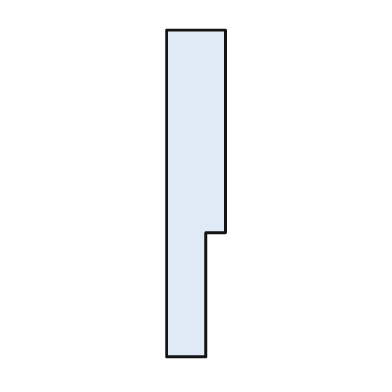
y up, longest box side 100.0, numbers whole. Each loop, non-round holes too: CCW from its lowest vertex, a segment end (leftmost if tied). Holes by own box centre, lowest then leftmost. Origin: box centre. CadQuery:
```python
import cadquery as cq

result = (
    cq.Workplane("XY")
    .moveTo(-9.0, -50.0)
    .lineTo(3.0, -50.0)
    .lineTo(3.0, -12.0)
    .lineTo(9.0, -12.0)
    .lineTo(9.0, 50.0)
    .lineTo(-9.0, 50.0)
    .close()
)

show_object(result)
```